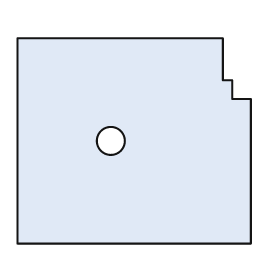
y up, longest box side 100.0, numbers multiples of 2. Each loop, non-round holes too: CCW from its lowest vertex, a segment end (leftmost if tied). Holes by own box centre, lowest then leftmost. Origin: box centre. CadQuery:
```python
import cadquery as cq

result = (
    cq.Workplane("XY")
    .moveTo(-50.0, -44.0)
    .lineTo(50.0, -44.0)
    .lineTo(50.0, 18.0)
    .lineTo(42.0, 18.0)
    .lineTo(42.0, 26.0)
    .lineTo(38.0, 26.0)
    .lineTo(38.0, 44.0)
    .lineTo(-50.0, 44.0)
    .close()
    .moveTo(-10.0, 0.0)
    .circle(6.0)
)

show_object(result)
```